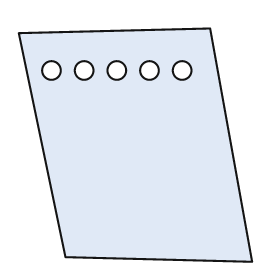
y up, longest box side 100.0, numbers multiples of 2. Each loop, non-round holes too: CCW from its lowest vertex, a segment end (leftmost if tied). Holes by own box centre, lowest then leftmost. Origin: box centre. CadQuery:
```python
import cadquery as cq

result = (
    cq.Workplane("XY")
    .moveTo(50.0, -50.0)
    .lineTo(32.0, 50.0)
    .lineTo(-50.0, 48.0)
    .lineTo(-30.0, -48.0)
    .close()
    .moveTo(-36.0, 32.0)
    .circle(4.0)
    .moveTo(-22.0, 32.0)
    .circle(4.0)
    .moveTo(-8.0, 32.0)
    .circle(4.0)
    .moveTo(6.0, 32.0)
    .circle(4.0)
    .moveTo(20.0, 32.0)
    .circle(4.0)
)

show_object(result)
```